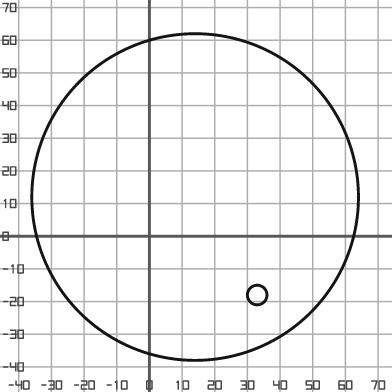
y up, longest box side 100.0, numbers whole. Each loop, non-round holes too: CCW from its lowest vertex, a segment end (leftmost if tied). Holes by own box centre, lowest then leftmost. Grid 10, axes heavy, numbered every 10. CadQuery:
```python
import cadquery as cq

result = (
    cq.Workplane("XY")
    .moveTo(14.0, 12.0)
    .circle(50.0)
    .moveTo(33.0, -18.0)
    .circle(3.0)
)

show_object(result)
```